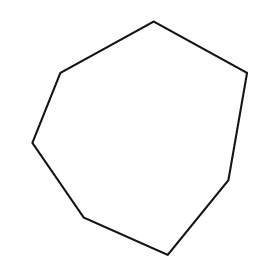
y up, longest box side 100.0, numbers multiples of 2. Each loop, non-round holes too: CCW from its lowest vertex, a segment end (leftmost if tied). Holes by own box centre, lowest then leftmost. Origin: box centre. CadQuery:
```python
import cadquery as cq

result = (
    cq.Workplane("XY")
    .moveTo(12.0, -50.0)
    .lineTo(38.0, -18.0)
    .lineTo(46.0, 28.0)
    .lineTo(6.0, 50.0)
    .lineTo(-34.0, 28.0)
    .lineTo(-46.0, -2.0)
    .lineTo(-24.0, -34.0)
    .close()
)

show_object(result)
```